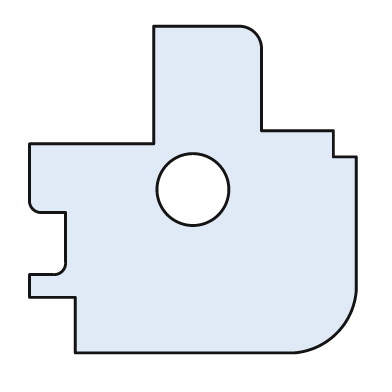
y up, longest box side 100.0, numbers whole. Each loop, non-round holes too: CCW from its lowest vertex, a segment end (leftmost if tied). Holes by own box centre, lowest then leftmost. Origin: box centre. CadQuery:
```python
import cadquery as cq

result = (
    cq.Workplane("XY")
    .moveTo(-36.0, -50.0)
    .lineTo(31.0, -50.0)
    .threePointArc((44.0, -44.0), (50.0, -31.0))
    .lineTo(50.0, 10.0)
    .lineTo(43.0, 10.0)
    .lineTo(43.0, 18.0)
    .lineTo(21.0, 18.0)
    .lineTo(21.0, 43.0)
    .threePointArc((19.0, 48.0), (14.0, 50.0))
    .lineTo(-12.0, 50.0)
    .lineTo(-12.0, 14.0)
    .lineTo(-50.0, 14.0)
    .lineTo(-50.0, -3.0)
    .threePointArc((-49.0, -6.0), (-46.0, -7.0))
    .lineTo(-39.0, -7.0)
    .lineTo(-39.0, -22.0)
    .threePointArc((-40.0, -25.0), (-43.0, -26.0))
    .lineTo(-50.0, -26.0)
    .lineTo(-50.0, -33.0)
    .lineTo(-36.0, -33.0)
    .close()
    .moveTo(0.0, 0.0)
    .circle(11.0)
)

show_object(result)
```